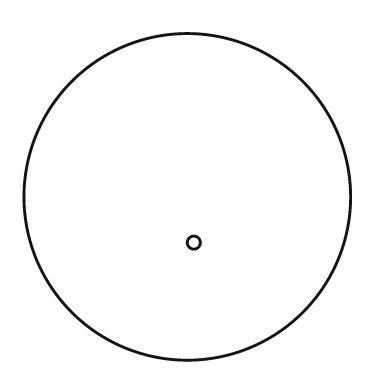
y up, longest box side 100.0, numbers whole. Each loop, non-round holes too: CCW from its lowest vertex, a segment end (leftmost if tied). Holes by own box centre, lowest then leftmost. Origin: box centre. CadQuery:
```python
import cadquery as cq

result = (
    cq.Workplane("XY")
    .moveTo(0.0, 0.0)
    .circle(50.0)
    .moveTo(2.0, -14.0)
    .circle(2.0)
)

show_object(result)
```